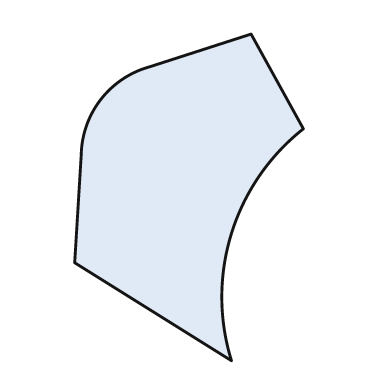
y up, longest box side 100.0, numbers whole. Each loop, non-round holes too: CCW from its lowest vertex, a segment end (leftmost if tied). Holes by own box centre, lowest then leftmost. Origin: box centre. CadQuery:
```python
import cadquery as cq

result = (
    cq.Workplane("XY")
    .moveTo(13.0, -50.0)
    .threePointArc((13.0, -11.0), (35.0, 21.0))
    .lineTo(19.0, 50.0)
    .lineTo(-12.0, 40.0)
    .threePointArc((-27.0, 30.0), (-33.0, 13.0))
    .lineTo(-35.0, -20.0)
    .close()
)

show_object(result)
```